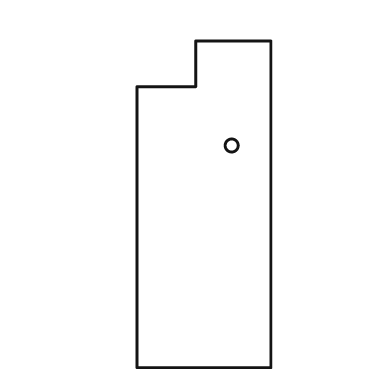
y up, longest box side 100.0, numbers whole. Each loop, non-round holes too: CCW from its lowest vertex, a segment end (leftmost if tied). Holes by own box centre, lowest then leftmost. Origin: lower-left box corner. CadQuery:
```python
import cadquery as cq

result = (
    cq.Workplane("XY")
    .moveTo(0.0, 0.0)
    .lineTo(41.0, 0.0)
    .lineTo(41.0, 100.0)
    .lineTo(18.0, 100.0)
    .lineTo(18.0, 86.0)
    .lineTo(0.0, 86.0)
    .close()
    .moveTo(29.0, 68.0)
    .circle(2.0)
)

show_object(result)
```